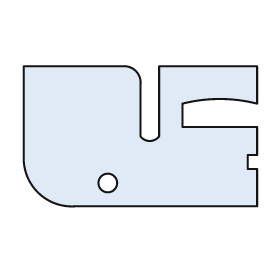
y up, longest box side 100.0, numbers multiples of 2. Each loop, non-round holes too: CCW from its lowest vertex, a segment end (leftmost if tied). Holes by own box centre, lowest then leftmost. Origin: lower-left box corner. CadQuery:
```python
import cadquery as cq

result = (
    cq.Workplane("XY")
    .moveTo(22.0, 0.0)
    .lineTo(100.0, 0.0)
    .lineTo(100.0, 16.0)
    .lineTo(96.0, 16.0)
    .lineTo(96.0, 22.0)
    .lineTo(100.0, 22.0)
    .lineTo(100.0, 34.0)
    .lineTo(68.0, 34.0)
    .lineTo(68.0, 44.0)
    .threePointArc((84.0, 46.0), (100.0, 44.0))
    .lineTo(100.0, 60.0)
    .lineTo(58.0, 60.0)
    .lineTo(58.0, 30.0)
    .threePointArc((54.0, 28.0), (50.0, 30.0))
    .lineTo(50.0, 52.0)
    .threePointArc((48.0, 58.0), (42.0, 60.0))
    .lineTo(0.0, 60.0)
    .lineTo(0.0, 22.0)
    .threePointArc((6.0, 6.0), (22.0, 0.0))
    .close()
    .moveTo(36.0, 10.0)
    .circle(4.0)
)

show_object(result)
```